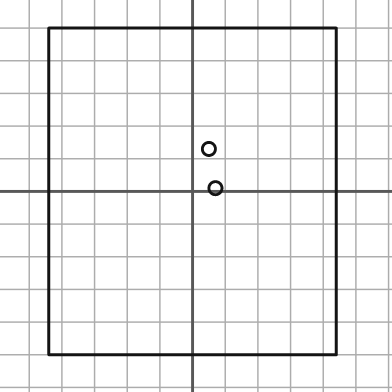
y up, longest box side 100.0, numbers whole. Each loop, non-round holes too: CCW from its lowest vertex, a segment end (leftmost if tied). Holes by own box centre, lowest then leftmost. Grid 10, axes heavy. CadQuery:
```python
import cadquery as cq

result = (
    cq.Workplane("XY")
    .moveTo(-44.0, -50.0)
    .lineTo(44.0, -50.0)
    .lineTo(44.0, 50.0)
    .lineTo(-44.0, 50.0)
    .close()
    .moveTo(7.0, 1.0)
    .circle(2.0)
    .moveTo(5.0, 13.0)
    .circle(2.0)
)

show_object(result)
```